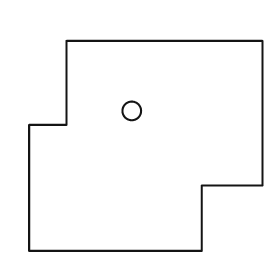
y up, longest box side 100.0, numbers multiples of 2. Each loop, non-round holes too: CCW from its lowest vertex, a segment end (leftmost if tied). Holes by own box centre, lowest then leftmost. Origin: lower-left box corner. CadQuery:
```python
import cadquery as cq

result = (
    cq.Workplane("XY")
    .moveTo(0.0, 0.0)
    .lineTo(74.0, 0.0)
    .lineTo(74.0, 28.0)
    .lineTo(100.0, 28.0)
    .lineTo(100.0, 90.0)
    .lineTo(16.0, 90.0)
    .lineTo(16.0, 54.0)
    .lineTo(0.0, 54.0)
    .close()
    .moveTo(44.0, 60.0)
    .circle(4.0)
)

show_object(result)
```